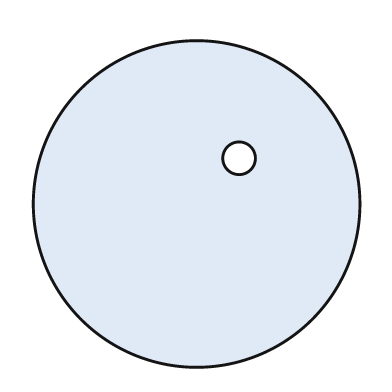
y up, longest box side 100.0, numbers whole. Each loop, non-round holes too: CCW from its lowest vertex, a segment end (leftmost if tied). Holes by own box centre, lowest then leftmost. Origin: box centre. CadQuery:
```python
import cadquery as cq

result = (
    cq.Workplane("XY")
    .moveTo(0.0, 0.0)
    .circle(50.0)
    .moveTo(13.0, 14.0)
    .circle(5.0)
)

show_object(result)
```